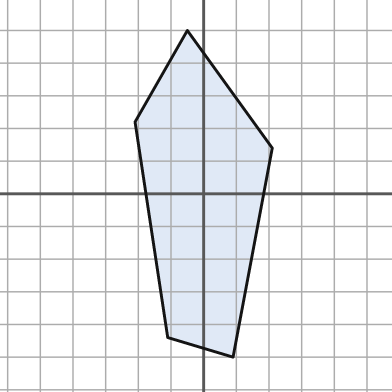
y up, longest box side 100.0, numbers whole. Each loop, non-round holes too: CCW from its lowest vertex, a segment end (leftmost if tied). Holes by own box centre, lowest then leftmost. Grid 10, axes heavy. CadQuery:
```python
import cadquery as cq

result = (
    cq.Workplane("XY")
    .moveTo(9.0, -50.0)
    .lineTo(21.0, 14.0)
    .lineTo(-5.0, 50.0)
    .lineTo(-21.0, 22.0)
    .lineTo(-11.0, -44.0)
    .close()
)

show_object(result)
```